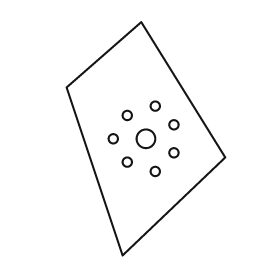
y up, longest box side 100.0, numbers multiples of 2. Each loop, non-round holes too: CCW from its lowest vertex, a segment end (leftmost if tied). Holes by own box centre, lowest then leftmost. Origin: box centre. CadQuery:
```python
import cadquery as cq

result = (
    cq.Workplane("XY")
    .moveTo(-10.0, -50.0)
    .lineTo(34.0, -8.0)
    .lineTo(-2.0, 50.0)
    .lineTo(-34.0, 22.0)
    .close()
    .moveTo(4.0, -14.0)
    .circle(2.0)
    .moveTo(-8.0, -10.0)
    .circle(2.0)
    .moveTo(12.0, -6.0)
    .circle(2.0)
    .moveTo(-14.0, 0.0)
    .circle(2.0)
    .moveTo(0.0, 0.0)
    .circle(4.0)
    .moveTo(12.0, 6.0)
    .circle(2.0)
    .moveTo(-8.0, 10.0)
    .circle(2.0)
    .moveTo(4.0, 14.0)
    .circle(2.0)
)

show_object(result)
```